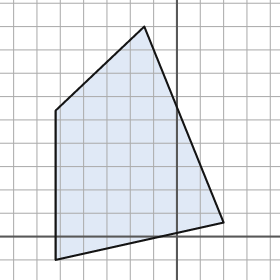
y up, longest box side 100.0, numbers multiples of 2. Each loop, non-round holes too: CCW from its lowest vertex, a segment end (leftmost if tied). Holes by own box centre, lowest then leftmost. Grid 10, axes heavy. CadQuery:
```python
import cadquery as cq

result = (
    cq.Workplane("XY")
    .moveTo(-52.0, -10.0)
    .lineTo(20.0, 6.0)
    .lineTo(-14.0, 90.0)
    .lineTo(-52.0, 54.0)
    .close()
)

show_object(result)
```